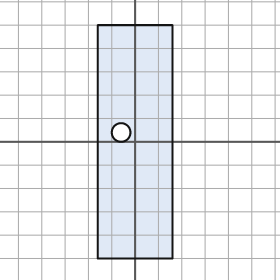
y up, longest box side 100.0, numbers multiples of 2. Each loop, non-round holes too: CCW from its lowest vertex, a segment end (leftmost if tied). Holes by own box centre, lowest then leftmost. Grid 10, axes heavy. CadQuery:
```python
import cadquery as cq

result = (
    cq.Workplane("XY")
    .moveTo(-16.0, -50.0)
    .lineTo(16.0, -50.0)
    .lineTo(16.0, 50.0)
    .lineTo(-16.0, 50.0)
    .close()
    .moveTo(-6.0, 4.0)
    .circle(4.0)
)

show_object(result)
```